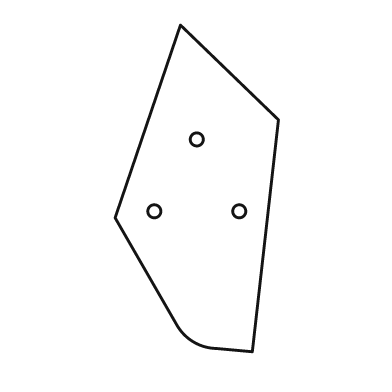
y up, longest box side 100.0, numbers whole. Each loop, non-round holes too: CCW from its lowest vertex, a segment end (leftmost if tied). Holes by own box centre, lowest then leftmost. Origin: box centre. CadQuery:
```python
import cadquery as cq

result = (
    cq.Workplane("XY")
    .moveTo(17.0, -50.0)
    .lineTo(25.0, 21.0)
    .lineTo(-5.0, 50.0)
    .lineTo(-25.0, -9.0)
    .lineTo(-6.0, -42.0)
    .threePointArc((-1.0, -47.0), (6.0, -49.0))
    .close()
    .moveTo(-13.0, -7.0)
    .circle(2.0)
    .moveTo(13.0, -7.0)
    .circle(2.0)
    .moveTo(0.0, 15.0)
    .circle(2.0)
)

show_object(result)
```